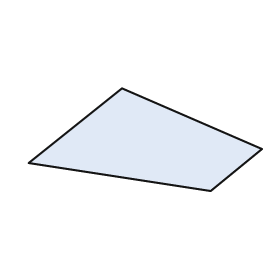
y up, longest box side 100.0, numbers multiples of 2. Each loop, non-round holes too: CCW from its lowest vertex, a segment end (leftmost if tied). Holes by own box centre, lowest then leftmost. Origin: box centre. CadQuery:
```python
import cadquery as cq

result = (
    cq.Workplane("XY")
    .moveTo(28.0, -22.0)
    .lineTo(50.0, -4.0)
    .lineTo(-10.0, 22.0)
    .lineTo(-50.0, -10.0)
    .close()
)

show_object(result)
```